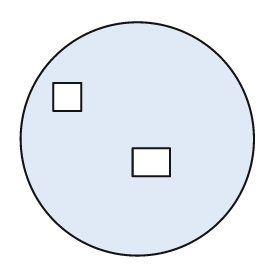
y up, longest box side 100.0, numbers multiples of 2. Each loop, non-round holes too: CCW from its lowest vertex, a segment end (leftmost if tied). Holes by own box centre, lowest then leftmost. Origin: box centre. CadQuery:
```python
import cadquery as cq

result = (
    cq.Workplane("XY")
    .moveTo(0.0, 0.0)
    .circle(50.0)
    .moveTo(-2.0, -16.0)
    .lineTo(14.0, -16.0)
    .lineTo(14.0, -4.0)
    .lineTo(-2.0, -4.0)
    .close()
    .moveTo(-36.0, 12.0)
    .lineTo(-24.0, 12.0)
    .lineTo(-24.0, 24.0)
    .lineTo(-36.0, 24.0)
    .close()
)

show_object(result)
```